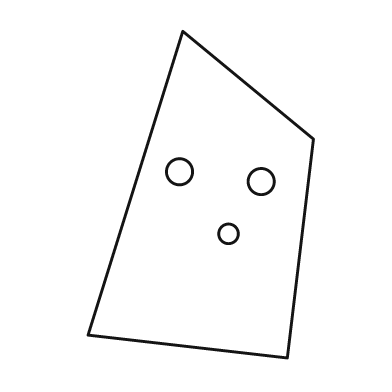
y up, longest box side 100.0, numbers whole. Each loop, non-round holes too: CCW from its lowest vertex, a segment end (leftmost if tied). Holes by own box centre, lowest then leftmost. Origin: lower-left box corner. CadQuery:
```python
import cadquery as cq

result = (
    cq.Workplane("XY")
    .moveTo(61.0, 0.0)
    .lineTo(69.0, 67.0)
    .lineTo(29.0, 100.0)
    .lineTo(0.0, 7.0)
    .close()
    .moveTo(43.0, 38.0)
    .circle(3.0)
    .moveTo(53.0, 54.0)
    .circle(4.0)
    .moveTo(28.0, 57.0)
    .circle(4.0)
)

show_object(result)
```